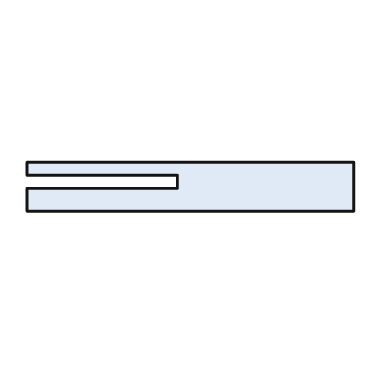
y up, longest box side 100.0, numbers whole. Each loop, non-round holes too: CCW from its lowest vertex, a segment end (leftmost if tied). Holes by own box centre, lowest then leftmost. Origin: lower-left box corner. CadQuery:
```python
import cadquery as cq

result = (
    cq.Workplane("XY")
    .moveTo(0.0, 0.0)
    .lineTo(100.0, 0.0)
    .lineTo(100.0, 15.0)
    .lineTo(0.0, 15.0)
    .lineTo(0.0, 11.0)
    .lineTo(46.0, 11.0)
    .lineTo(46.0, 7.0)
    .lineTo(0.0, 7.0)
    .close()
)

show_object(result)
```